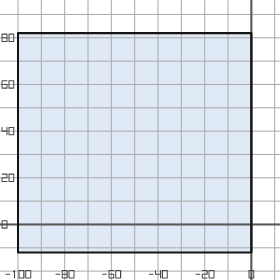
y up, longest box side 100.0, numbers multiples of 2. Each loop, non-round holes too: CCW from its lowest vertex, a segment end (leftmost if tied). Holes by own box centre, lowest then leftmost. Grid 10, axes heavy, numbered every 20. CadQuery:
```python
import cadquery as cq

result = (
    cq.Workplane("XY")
    .moveTo(-100.0, -12.0)
    .lineTo(0.0, -12.0)
    .lineTo(0.0, 82.0)
    .lineTo(-100.0, 82.0)
    .close()
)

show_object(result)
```